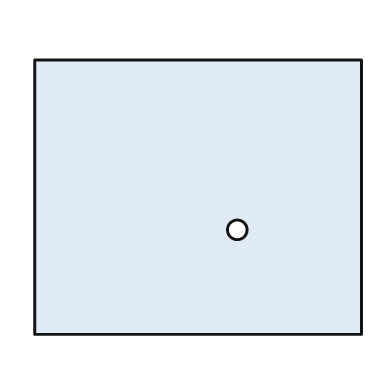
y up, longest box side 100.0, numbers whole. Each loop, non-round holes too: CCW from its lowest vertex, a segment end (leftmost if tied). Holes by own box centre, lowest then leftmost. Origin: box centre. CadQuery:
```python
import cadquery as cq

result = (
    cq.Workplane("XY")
    .moveTo(-50.0, -42.0)
    .lineTo(50.0, -42.0)
    .lineTo(50.0, 42.0)
    .lineTo(-50.0, 42.0)
    .close()
    .moveTo(12.0, -10.0)
    .circle(3.0)
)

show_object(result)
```